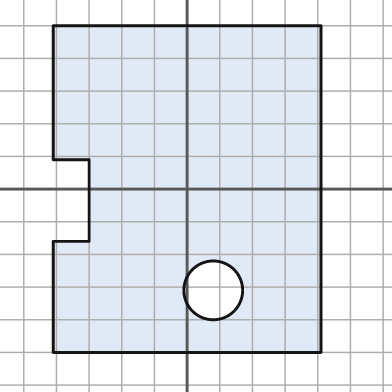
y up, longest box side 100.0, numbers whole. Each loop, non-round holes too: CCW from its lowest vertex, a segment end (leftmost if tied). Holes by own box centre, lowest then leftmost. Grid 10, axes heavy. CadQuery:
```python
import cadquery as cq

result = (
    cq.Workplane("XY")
    .moveTo(-41.0, -50.0)
    .lineTo(41.0, -50.0)
    .lineTo(41.0, 50.0)
    .lineTo(-41.0, 50.0)
    .lineTo(-41.0, 9.0)
    .lineTo(-30.0, 9.0)
    .lineTo(-30.0, -16.0)
    .lineTo(-41.0, -16.0)
    .close()
    .moveTo(8.0, -31.0)
    .circle(9.0)
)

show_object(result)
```